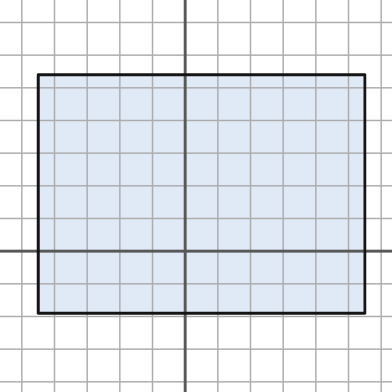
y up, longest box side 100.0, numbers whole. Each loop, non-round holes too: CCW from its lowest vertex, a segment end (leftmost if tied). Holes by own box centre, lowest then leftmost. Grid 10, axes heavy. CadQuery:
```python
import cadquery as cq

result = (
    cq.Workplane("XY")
    .moveTo(-45.0, -19.0)
    .lineTo(55.0, -19.0)
    .lineTo(55.0, 54.0)
    .lineTo(-45.0, 54.0)
    .close()
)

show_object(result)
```